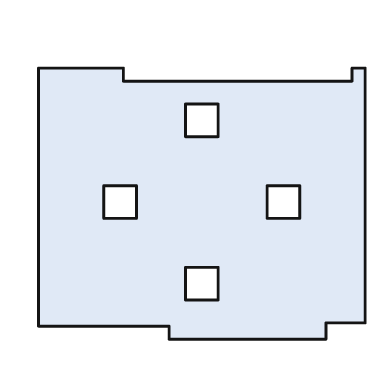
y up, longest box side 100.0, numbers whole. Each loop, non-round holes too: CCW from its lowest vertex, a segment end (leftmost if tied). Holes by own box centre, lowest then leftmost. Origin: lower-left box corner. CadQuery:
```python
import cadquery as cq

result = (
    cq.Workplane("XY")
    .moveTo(40.0, 0.0)
    .lineTo(88.0, 0.0)
    .lineTo(88.0, 5.0)
    .lineTo(100.0, 5.0)
    .lineTo(100.0, 83.0)
    .lineTo(96.0, 83.0)
    .lineTo(96.0, 79.0)
    .lineTo(26.0, 79.0)
    .lineTo(26.0, 83.0)
    .lineTo(0.0, 83.0)
    .lineTo(0.0, 4.0)
    .lineTo(40.0, 4.0)
    .close()
    .moveTo(45.0, 12.0)
    .lineTo(55.0, 12.0)
    .lineTo(55.0, 22.0)
    .lineTo(45.0, 22.0)
    .close()
    .moveTo(20.0, 37.0)
    .lineTo(30.0, 37.0)
    .lineTo(30.0, 47.0)
    .lineTo(20.0, 47.0)
    .close()
    .moveTo(70.0, 37.0)
    .lineTo(80.0, 37.0)
    .lineTo(80.0, 47.0)
    .lineTo(70.0, 47.0)
    .close()
    .moveTo(45.0, 62.0)
    .lineTo(55.0, 62.0)
    .lineTo(55.0, 72.0)
    .lineTo(45.0, 72.0)
    .close()
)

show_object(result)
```